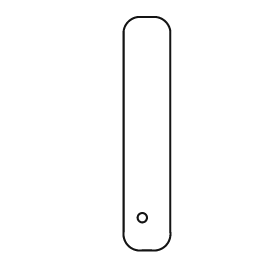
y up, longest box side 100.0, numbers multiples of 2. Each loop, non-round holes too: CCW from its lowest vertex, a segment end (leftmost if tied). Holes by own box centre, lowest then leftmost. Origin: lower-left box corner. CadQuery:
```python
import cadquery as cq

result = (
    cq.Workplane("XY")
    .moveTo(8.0, 0.0)
    .lineTo(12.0, 0.0)
    .threePointArc((18.0, 2.0), (20.0, 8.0))
    .lineTo(20.0, 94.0)
    .threePointArc((18.0, 98.0), (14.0, 100.0))
    .lineTo(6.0, 100.0)
    .threePointArc((2.0, 98.0), (0.0, 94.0))
    .lineTo(0.0, 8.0)
    .threePointArc((2.0, 2.0), (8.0, 0.0))
    .close()
    .moveTo(8.0, 14.0)
    .circle(2.0)
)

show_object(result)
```